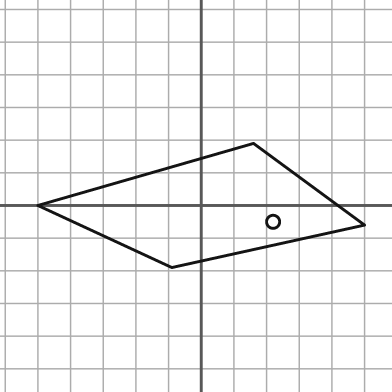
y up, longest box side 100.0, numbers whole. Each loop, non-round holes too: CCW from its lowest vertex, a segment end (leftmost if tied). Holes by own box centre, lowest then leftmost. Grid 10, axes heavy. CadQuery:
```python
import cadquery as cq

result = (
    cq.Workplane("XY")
    .moveTo(-9.0, -19.0)
    .lineTo(50.0, -6.0)
    .lineTo(16.0, 19.0)
    .lineTo(-50.0, 0.0)
    .close()
    .moveTo(22.0, -5.0)
    .circle(2.0)
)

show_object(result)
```